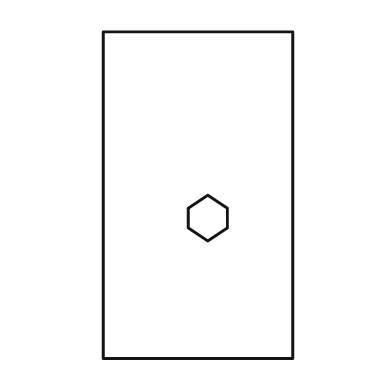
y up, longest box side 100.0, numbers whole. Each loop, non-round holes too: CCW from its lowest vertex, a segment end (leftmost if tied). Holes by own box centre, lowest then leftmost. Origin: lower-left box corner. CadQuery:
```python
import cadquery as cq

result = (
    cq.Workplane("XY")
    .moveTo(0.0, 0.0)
    .lineTo(58.0, 0.0)
    .lineTo(58.0, 100.0)
    .lineTo(0.0, 100.0)
    .close()
    .moveTo(32.0, 36.0)
    .lineTo(38.0, 40.0)
    .lineTo(38.0, 46.0)
    .lineTo(32.0, 50.0)
    .lineTo(26.0, 46.0)
    .lineTo(26.0, 40.0)
    .close()
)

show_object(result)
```